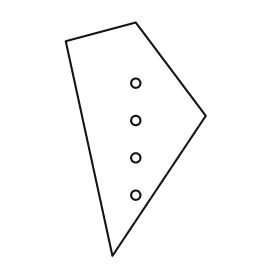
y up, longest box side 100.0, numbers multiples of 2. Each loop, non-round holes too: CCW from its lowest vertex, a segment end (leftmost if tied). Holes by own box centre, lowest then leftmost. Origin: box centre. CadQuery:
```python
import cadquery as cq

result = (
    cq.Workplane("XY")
    .moveTo(-10.0, -50.0)
    .lineTo(30.0, 10.0)
    .lineTo(0.0, 50.0)
    .lineTo(-30.0, 42.0)
    .close()
    .moveTo(0.0, -24.0)
    .circle(2.0)
    .moveTo(0.0, -8.0)
    .circle(2.0)
    .moveTo(0.0, 8.0)
    .circle(2.0)
    .moveTo(0.0, 24.0)
    .circle(2.0)
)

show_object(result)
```